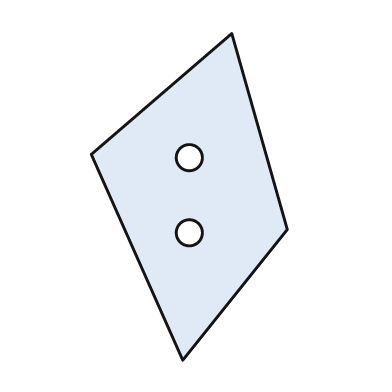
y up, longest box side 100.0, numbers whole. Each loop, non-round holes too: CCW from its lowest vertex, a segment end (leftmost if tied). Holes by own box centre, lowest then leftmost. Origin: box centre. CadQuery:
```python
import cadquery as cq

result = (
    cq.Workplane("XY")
    .moveTo(-2.0, -50.0)
    .lineTo(30.0, -10.0)
    .lineTo(13.0, 50.0)
    .lineTo(-30.0, 13.0)
    .close()
    .moveTo(0.0, -11.0)
    .circle(4.0)
    .moveTo(0.0, 12.0)
    .circle(4.0)
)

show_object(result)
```